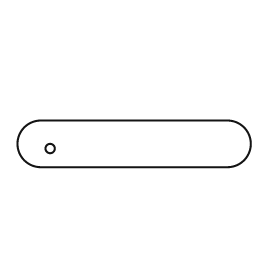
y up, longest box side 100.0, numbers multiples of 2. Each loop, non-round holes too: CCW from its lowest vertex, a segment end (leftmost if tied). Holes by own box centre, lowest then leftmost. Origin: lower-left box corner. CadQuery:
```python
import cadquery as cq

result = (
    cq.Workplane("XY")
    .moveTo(10.0, 0.0)
    .lineTo(90.0, 0.0)
    .threePointArc((100.0, 10.0), (90.0, 20.0))
    .lineTo(10.0, 20.0)
    .threePointArc((0.0, 10.0), (10.0, 0.0))
    .close()
    .moveTo(14.0, 8.0)
    .circle(2.0)
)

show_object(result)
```